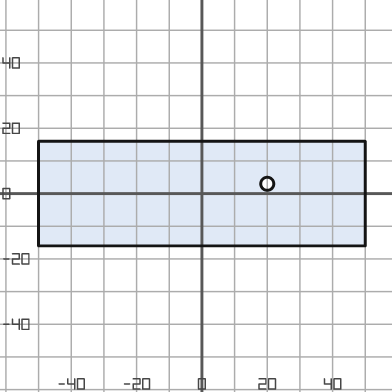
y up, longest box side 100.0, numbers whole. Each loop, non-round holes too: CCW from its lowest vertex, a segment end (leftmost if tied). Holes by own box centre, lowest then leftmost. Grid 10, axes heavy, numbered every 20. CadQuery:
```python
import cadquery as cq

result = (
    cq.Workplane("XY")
    .moveTo(-50.0, -16.0)
    .lineTo(50.0, -16.0)
    .lineTo(50.0, 16.0)
    .lineTo(-50.0, 16.0)
    .close()
    .moveTo(20.0, 3.0)
    .circle(2.0)
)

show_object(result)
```